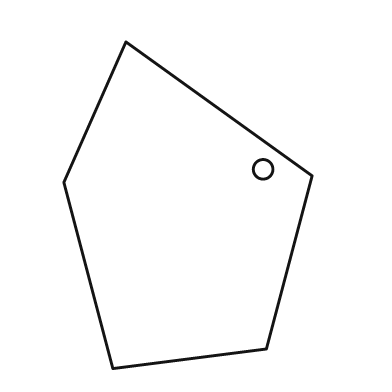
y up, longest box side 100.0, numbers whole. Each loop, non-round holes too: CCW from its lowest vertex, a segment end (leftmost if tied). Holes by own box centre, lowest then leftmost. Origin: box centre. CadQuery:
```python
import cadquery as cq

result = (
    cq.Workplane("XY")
    .moveTo(-23.0, -50.0)
    .lineTo(24.0, -44.0)
    .lineTo(38.0, 9.0)
    .lineTo(-19.0, 50.0)
    .lineTo(-38.0, 7.0)
    .close()
    .moveTo(23.0, 11.0)
    .circle(3.0)
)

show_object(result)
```